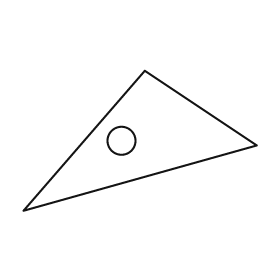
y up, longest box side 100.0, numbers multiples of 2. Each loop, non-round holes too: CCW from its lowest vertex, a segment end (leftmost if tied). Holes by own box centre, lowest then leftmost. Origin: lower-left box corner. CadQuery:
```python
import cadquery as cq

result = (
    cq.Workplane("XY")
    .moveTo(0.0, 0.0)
    .lineTo(100.0, 28.0)
    .lineTo(52.0, 60.0)
    .close()
    .moveTo(42.0, 30.0)
    .circle(6.0)
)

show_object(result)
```